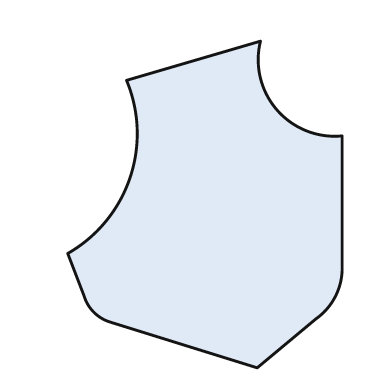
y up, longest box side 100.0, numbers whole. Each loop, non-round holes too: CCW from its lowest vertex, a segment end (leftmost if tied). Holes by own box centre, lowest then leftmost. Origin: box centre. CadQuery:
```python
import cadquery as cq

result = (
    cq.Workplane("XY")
    .moveTo(16.0, -50.0)
    .lineTo(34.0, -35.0)
    .threePointArc((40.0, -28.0), (42.0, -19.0))
    .lineTo(42.0, 21.0)
    .threePointArc((22.0, 29.0), (17.0, 50.0))
    .lineTo(-24.0, 38.0)
    .threePointArc((-23.0, 8.0), (-42.0, -15.0))
    .lineTo(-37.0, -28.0)
    .threePointArc((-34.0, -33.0), (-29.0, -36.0))
    .close()
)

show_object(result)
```